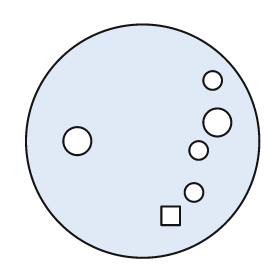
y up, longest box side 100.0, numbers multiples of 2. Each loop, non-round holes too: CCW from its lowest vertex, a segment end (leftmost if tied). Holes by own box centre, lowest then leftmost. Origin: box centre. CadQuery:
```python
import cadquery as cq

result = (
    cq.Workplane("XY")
    .moveTo(0.0, 0.0)
    .circle(50.0)
    .moveTo(8.0, -36.0)
    .lineTo(16.0, -36.0)
    .lineTo(16.0, -28.0)
    .lineTo(8.0, -28.0)
    .close()
    .moveTo(22.0, -22.0)
    .circle(4.0)
    .moveTo(24.0, -4.0)
    .circle(4.0)
    .moveTo(-28.0, 0.0)
    .circle(6.0)
    .moveTo(32.0, 8.0)
    .circle(6.0)
    .moveTo(30.0, 26.0)
    .circle(4.0)
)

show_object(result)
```